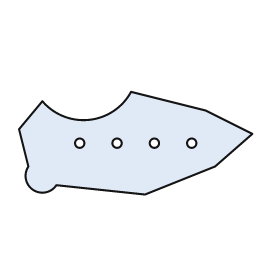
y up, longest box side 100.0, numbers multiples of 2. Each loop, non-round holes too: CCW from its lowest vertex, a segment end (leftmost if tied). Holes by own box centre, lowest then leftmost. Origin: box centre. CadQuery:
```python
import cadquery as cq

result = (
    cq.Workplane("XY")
    .moveTo(4.0, -22.0)
    .lineTo(34.0, -10.0)
    .lineTo(50.0, 4.0)
    .lineTo(30.0, 14.0)
    .lineTo(-2.0, 22.0)
    .threePointArc((-20.0, 10.0), (-40.0, 18.0))
    .lineTo(-50.0, 6.0)
    .lineTo(-46.0, -10.0)
    .threePointArc((-44.0, -20.0), (-34.0, -18.0))
    .close()
    .moveTo(-24.0, 0.0)
    .circle(2.0)
    .moveTo(-8.0, 0.0)
    .circle(2.0)
    .moveTo(8.0, 0.0)
    .circle(2.0)
    .moveTo(24.0, 0.0)
    .circle(2.0)
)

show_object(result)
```